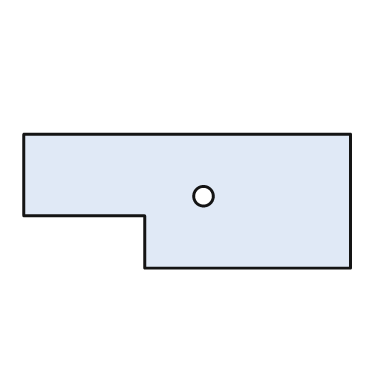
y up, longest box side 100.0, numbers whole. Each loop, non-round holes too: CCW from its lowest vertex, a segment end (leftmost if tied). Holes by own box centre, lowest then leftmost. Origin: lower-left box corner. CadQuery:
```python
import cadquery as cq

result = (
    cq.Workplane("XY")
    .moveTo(37.0, 0.0)
    .lineTo(100.0, 0.0)
    .lineTo(100.0, 41.0)
    .lineTo(0.0, 41.0)
    .lineTo(0.0, 16.0)
    .lineTo(37.0, 16.0)
    .close()
    .moveTo(55.0, 22.0)
    .circle(3.0)
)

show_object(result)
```